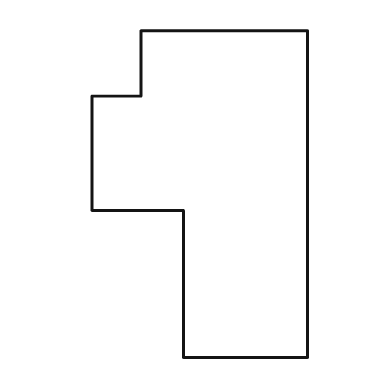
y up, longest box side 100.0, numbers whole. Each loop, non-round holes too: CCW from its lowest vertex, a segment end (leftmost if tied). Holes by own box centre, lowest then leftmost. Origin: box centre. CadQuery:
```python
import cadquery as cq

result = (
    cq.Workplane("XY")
    .moveTo(-5.0, -50.0)
    .lineTo(33.0, -50.0)
    .lineTo(33.0, 50.0)
    .lineTo(-18.0, 50.0)
    .lineTo(-18.0, 30.0)
    .lineTo(-33.0, 30.0)
    .lineTo(-33.0, -5.0)
    .lineTo(-5.0, -5.0)
    .close()
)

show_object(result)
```